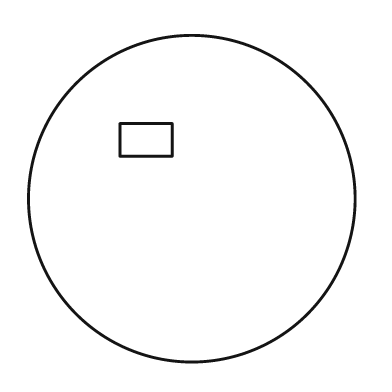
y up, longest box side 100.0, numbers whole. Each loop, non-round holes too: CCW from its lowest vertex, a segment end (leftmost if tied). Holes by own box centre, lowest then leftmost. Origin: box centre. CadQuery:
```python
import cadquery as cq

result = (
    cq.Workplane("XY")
    .moveTo(0.0, 0.0)
    .circle(50.0)
    .moveTo(-22.0, 13.0)
    .lineTo(-6.0, 13.0)
    .lineTo(-6.0, 23.0)
    .lineTo(-22.0, 23.0)
    .close()
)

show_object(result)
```